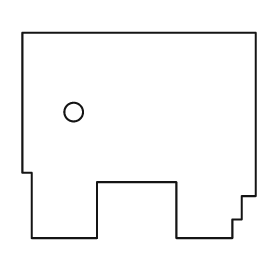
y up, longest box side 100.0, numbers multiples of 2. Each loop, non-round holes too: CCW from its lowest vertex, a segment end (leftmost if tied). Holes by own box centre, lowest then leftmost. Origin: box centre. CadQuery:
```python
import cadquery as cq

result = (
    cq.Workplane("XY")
    .moveTo(-46.0, -44.0)
    .lineTo(-18.0, -44.0)
    .lineTo(-18.0, -20.0)
    .lineTo(16.0, -20.0)
    .lineTo(16.0, -44.0)
    .lineTo(40.0, -44.0)
    .lineTo(40.0, -36.0)
    .lineTo(44.0, -36.0)
    .lineTo(44.0, -26.0)
    .lineTo(50.0, -26.0)
    .lineTo(50.0, 44.0)
    .lineTo(-50.0, 44.0)
    .lineTo(-50.0, -16.0)
    .lineTo(-46.0, -16.0)
    .close()
    .moveTo(-28.0, 10.0)
    .circle(4.0)
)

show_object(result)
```